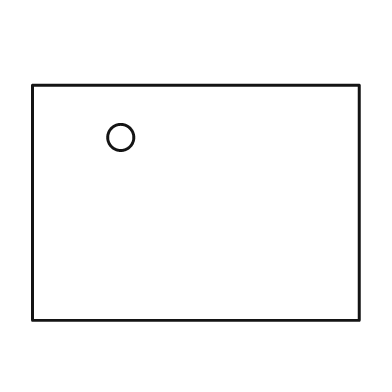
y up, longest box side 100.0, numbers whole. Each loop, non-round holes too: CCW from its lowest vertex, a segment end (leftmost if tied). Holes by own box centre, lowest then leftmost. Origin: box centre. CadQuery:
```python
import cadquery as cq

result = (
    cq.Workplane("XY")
    .moveTo(-50.0, -36.0)
    .lineTo(50.0, -36.0)
    .lineTo(50.0, 36.0)
    .lineTo(-50.0, 36.0)
    .close()
    .moveTo(-23.0, 20.0)
    .circle(4.0)
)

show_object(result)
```